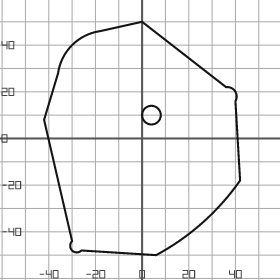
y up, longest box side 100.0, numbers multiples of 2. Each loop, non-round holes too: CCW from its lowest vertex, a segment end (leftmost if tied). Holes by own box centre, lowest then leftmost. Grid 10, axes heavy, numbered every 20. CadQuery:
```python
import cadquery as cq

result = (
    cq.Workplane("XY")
    .moveTo(6.0, -50.0)
    .threePointArc((26.0, -36.0), (42.0, -18.0))
    .lineTo(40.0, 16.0)
    .threePointArc((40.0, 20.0), (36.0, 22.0))
    .lineTo(0.0, 50.0)
    .lineTo(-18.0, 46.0)
    .threePointArc((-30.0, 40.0), (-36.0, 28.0))
    .lineTo(-42.0, 8.0)
    .lineTo(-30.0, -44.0)
    .threePointArc((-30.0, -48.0), (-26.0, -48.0))
    .close()
    .moveTo(4.0, 10.0)
    .circle(4.0)
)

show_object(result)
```